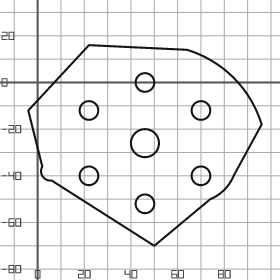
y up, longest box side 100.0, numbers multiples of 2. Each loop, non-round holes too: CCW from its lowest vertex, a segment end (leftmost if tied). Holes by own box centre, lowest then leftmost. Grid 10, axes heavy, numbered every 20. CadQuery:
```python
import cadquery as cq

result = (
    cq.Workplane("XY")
    .moveTo(50.0, -70.0)
    .lineTo(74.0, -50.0)
    .threePointArc((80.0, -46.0), (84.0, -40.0))
    .lineTo(96.0, -18.0)
    .threePointArc((84.0, 2.0), (64.0, 14.0))
    .lineTo(22.0, 16.0)
    .lineTo(-4.0, -12.0)
    .lineTo(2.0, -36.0)
    .threePointArc((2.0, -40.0), (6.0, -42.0))
    .close()
    .moveTo(46.0, -52.0)
    .circle(4.0)
    .moveTo(22.0, -40.0)
    .circle(4.0)
    .moveTo(70.0, -40.0)
    .circle(4.0)
    .moveTo(46.0, -26.0)
    .circle(6.0)
    .moveTo(22.0, -12.0)
    .circle(4.0)
    .moveTo(70.0, -12.0)
    .circle(4.0)
    .moveTo(46.0, 0.0)
    .circle(4.0)
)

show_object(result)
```